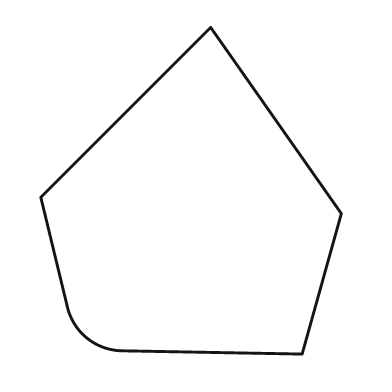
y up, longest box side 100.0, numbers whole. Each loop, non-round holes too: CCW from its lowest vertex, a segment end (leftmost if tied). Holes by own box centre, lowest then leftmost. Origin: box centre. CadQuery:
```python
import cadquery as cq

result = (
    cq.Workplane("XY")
    .moveTo(34.0, -50.0)
    .lineTo(46.0, -7.0)
    .lineTo(6.0, 50.0)
    .lineTo(-46.0, -2.0)
    .lineTo(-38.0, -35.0)
    .threePointArc((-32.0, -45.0), (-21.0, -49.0))
    .close()
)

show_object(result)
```